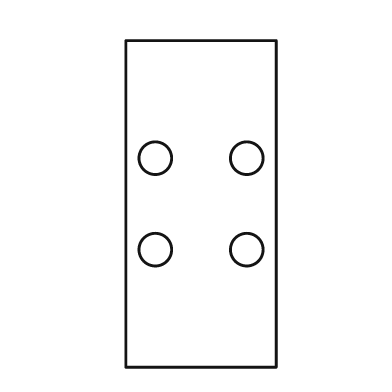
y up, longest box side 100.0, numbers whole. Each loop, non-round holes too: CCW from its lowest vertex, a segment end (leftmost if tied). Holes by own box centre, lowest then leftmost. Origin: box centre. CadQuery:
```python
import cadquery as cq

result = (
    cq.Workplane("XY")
    .moveTo(-23.0, -50.0)
    .lineTo(23.0, -50.0)
    .lineTo(23.0, 50.0)
    .lineTo(-23.0, 50.0)
    .close()
    .moveTo(-14.0, -14.0)
    .circle(5.0)
    .moveTo(14.0, -14.0)
    .circle(5.0)
    .moveTo(-14.0, 14.0)
    .circle(5.0)
    .moveTo(14.0, 14.0)
    .circle(5.0)
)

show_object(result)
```